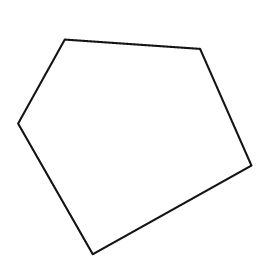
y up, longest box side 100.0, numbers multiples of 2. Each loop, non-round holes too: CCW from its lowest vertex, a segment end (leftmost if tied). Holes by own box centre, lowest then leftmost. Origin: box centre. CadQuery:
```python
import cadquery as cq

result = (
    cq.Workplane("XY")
    .moveTo(-18.0, -46.0)
    .lineTo(50.0, -8.0)
    .lineTo(28.0, 42.0)
    .lineTo(-30.0, 46.0)
    .lineTo(-50.0, 10.0)
    .close()
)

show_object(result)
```